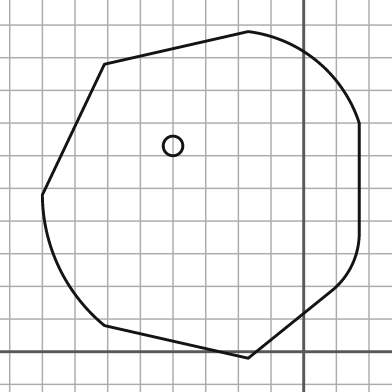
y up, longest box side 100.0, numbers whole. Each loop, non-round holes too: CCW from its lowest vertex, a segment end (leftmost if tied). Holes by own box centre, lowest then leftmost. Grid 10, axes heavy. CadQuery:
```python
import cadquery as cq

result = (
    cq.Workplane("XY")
    .moveTo(-17.0, -2.0)
    .lineTo(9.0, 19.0)
    .threePointArc((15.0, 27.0), (17.0, 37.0))
    .lineTo(17.0, 70.0)
    .threePointArc((4.0, 89.0), (-17.0, 98.0))
    .lineTo(-61.0, 88.0)
    .lineTo(-80.0, 48.0)
    .threePointArc((-75.0, 26.0), (-61.0, 8.0))
    .close()
    .moveTo(-40.0, 63.0)
    .circle(3.0)
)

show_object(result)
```